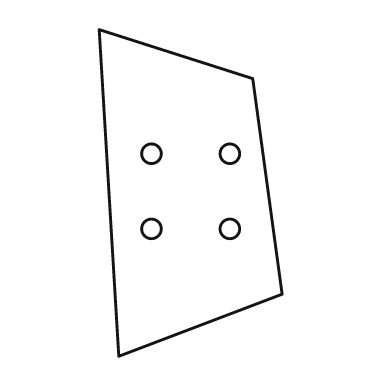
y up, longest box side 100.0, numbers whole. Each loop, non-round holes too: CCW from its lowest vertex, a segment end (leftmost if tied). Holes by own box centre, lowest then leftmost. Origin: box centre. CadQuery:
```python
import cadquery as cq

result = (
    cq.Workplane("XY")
    .moveTo(-22.0, -50.0)
    .lineTo(28.0, -31.0)
    .lineTo(19.0, 35.0)
    .lineTo(-28.0, 50.0)
    .close()
    .moveTo(-12.0, -11.0)
    .circle(3.0)
    .moveTo(12.0, -11.0)
    .circle(3.0)
    .moveTo(-12.0, 12.0)
    .circle(3.0)
    .moveTo(12.0, 12.0)
    .circle(3.0)
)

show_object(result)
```